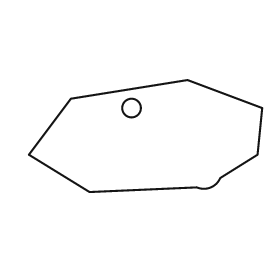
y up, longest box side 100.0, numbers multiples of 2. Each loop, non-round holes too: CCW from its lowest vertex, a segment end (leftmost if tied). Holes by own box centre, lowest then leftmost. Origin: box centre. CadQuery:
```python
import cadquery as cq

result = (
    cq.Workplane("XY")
    .moveTo(-24.0, -24.0)
    .lineTo(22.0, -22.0)
    .threePointArc((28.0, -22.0), (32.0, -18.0))
    .lineTo(48.0, -8.0)
    .lineTo(50.0, 12.0)
    .lineTo(18.0, 24.0)
    .lineTo(-32.0, 16.0)
    .lineTo(-50.0, -8.0)
    .close()
    .moveTo(-6.0, 12.0)
    .circle(4.0)
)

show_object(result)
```